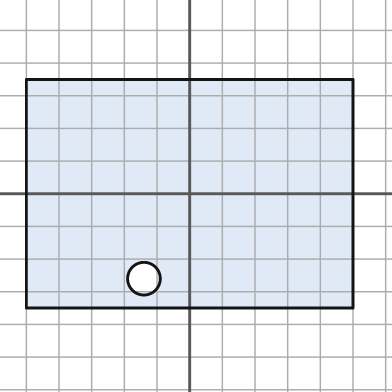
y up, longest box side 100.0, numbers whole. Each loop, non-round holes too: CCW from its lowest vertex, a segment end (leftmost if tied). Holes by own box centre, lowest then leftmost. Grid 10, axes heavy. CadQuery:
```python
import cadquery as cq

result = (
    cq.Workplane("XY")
    .moveTo(-50.0, -35.0)
    .lineTo(50.0, -35.0)
    .lineTo(50.0, 35.0)
    .lineTo(-50.0, 35.0)
    .close()
    .moveTo(-14.0, -26.0)
    .circle(5.0)
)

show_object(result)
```